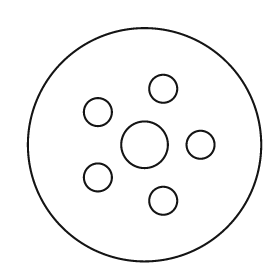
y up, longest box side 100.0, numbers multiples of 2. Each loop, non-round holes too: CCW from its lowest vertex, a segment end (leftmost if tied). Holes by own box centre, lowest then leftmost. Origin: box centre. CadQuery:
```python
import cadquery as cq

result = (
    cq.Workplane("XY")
    .moveTo(0.0, 0.0)
    .circle(50.0)
    .moveTo(8.0, -24.0)
    .circle(6.0)
    .moveTo(-20.0, -14.0)
    .circle(6.0)
    .moveTo(0.0, 0.0)
    .circle(10.0)
    .moveTo(24.0, 0.0)
    .circle(6.0)
    .moveTo(-20.0, 14.0)
    .circle(6.0)
    .moveTo(8.0, 24.0)
    .circle(6.0)
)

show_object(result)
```